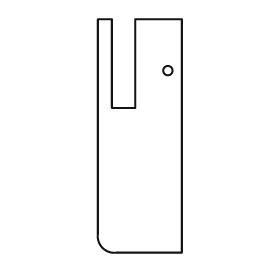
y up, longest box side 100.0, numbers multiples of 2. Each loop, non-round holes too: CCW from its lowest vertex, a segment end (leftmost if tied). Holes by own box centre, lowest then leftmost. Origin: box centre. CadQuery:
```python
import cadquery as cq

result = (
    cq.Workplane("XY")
    .moveTo(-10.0, -50.0)
    .lineTo(18.0, -50.0)
    .lineTo(18.0, 50.0)
    .lineTo(-2.0, 50.0)
    .lineTo(-2.0, 12.0)
    .lineTo(-12.0, 12.0)
    .lineTo(-12.0, 50.0)
    .lineTo(-18.0, 50.0)
    .lineTo(-18.0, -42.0)
    .threePointArc((-16.0, -48.0), (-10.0, -50.0))
    .close()
    .moveTo(12.0, 28.0)
    .circle(2.0)
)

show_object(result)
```